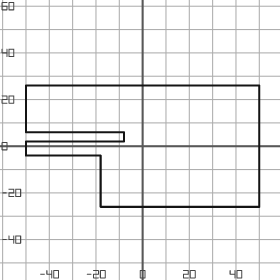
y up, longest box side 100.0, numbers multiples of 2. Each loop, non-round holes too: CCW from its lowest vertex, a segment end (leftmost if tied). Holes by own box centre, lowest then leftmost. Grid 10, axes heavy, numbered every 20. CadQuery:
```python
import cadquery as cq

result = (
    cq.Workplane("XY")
    .moveTo(-18.0, -26.0)
    .lineTo(50.0, -26.0)
    .lineTo(50.0, 26.0)
    .lineTo(-50.0, 26.0)
    .lineTo(-50.0, 6.0)
    .lineTo(-8.0, 6.0)
    .lineTo(-8.0, 2.0)
    .lineTo(-50.0, 2.0)
    .lineTo(-50.0, -4.0)
    .lineTo(-18.0, -4.0)
    .close()
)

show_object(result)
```